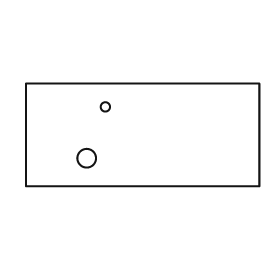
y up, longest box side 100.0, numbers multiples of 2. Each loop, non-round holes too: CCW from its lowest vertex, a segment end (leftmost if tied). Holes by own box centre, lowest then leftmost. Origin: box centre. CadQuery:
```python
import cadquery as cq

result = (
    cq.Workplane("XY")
    .moveTo(-50.0, -22.0)
    .lineTo(50.0, -22.0)
    .lineTo(50.0, 22.0)
    .lineTo(-50.0, 22.0)
    .close()
    .moveTo(-24.0, -10.0)
    .circle(4.0)
    .moveTo(-16.0, 12.0)
    .circle(2.0)
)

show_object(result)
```